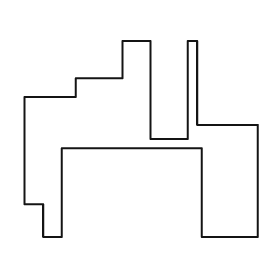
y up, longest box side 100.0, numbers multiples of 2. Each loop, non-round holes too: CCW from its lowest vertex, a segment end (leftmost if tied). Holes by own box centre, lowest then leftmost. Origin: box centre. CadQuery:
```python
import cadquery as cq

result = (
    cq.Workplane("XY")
    .moveTo(-42.0, -42.0)
    .lineTo(-34.0, -42.0)
    .lineTo(-34.0, -4.0)
    .lineTo(26.0, -4.0)
    .lineTo(26.0, -42.0)
    .lineTo(50.0, -42.0)
    .lineTo(50.0, 6.0)
    .lineTo(24.0, 6.0)
    .lineTo(24.0, 42.0)
    .lineTo(20.0, 42.0)
    .lineTo(20.0, 0.0)
    .lineTo(4.0, 0.0)
    .lineTo(4.0, 42.0)
    .lineTo(-8.0, 42.0)
    .lineTo(-8.0, 26.0)
    .lineTo(-28.0, 26.0)
    .lineTo(-28.0, 18.0)
    .lineTo(-50.0, 18.0)
    .lineTo(-50.0, -28.0)
    .lineTo(-42.0, -28.0)
    .close()
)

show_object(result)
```